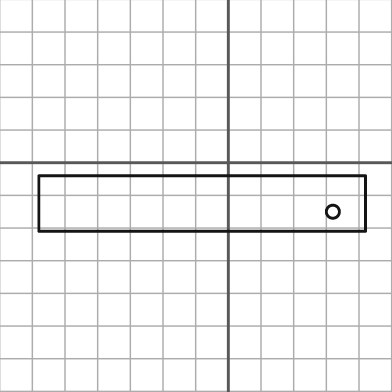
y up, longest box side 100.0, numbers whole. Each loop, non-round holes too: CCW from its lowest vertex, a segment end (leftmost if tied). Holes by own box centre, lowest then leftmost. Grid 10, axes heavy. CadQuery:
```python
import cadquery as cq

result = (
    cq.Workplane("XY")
    .moveTo(-58.0, -21.0)
    .lineTo(42.0, -21.0)
    .lineTo(42.0, -4.0)
    .lineTo(-58.0, -4.0)
    .close()
    .moveTo(32.0, -15.0)
    .circle(2.0)
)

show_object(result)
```